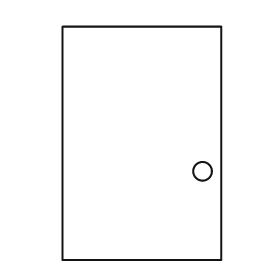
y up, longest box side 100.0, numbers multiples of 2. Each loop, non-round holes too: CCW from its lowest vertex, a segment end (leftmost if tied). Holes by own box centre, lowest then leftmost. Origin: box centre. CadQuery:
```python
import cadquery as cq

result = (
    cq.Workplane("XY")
    .moveTo(-34.0, -50.0)
    .lineTo(34.0, -50.0)
    .lineTo(34.0, 50.0)
    .lineTo(-34.0, 50.0)
    .close()
    .moveTo(26.0, -12.0)
    .circle(4.0)
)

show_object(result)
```